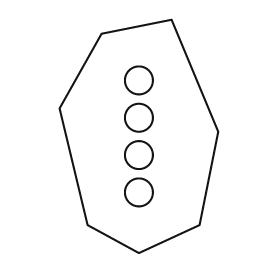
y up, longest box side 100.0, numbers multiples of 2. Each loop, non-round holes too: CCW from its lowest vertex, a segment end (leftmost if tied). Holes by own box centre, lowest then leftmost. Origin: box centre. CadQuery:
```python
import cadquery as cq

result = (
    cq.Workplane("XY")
    .moveTo(0.0, -50.0)
    .lineTo(26.0, -38.0)
    .lineTo(34.0, 2.0)
    .lineTo(14.0, 50.0)
    .lineTo(-16.0, 44.0)
    .lineTo(-34.0, 12.0)
    .lineTo(-22.0, -38.0)
    .close()
    .moveTo(0.0, -24.0)
    .circle(6.0)
    .moveTo(0.0, -8.0)
    .circle(6.0)
    .moveTo(0.0, 8.0)
    .circle(6.0)
    .moveTo(0.0, 24.0)
    .circle(6.0)
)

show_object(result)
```